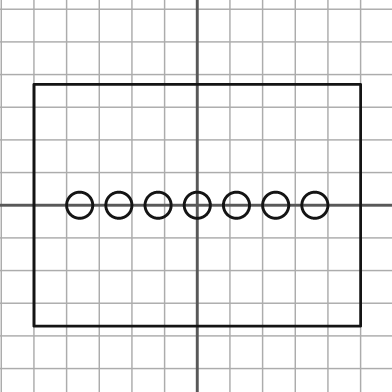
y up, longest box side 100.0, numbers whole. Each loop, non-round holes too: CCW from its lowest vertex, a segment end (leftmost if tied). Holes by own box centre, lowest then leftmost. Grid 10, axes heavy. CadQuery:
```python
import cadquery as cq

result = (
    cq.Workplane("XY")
    .moveTo(-50.0, -37.0)
    .lineTo(50.0, -37.0)
    .lineTo(50.0, 37.0)
    .lineTo(-50.0, 37.0)
    .close()
    .moveTo(-36.0, 0.0)
    .circle(4.0)
    .moveTo(-24.0, 0.0)
    .circle(4.0)
    .moveTo(-12.0, 0.0)
    .circle(4.0)
    .moveTo(0.0, 0.0)
    .circle(4.0)
    .moveTo(12.0, 0.0)
    .circle(4.0)
    .moveTo(24.0, 0.0)
    .circle(4.0)
    .moveTo(36.0, 0.0)
    .circle(4.0)
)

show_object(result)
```